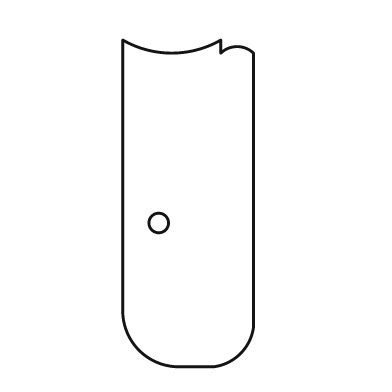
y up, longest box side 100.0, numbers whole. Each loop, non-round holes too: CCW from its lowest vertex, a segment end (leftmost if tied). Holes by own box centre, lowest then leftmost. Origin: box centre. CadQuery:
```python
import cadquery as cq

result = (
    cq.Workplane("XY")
    .moveTo(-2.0, -50.0)
    .lineTo(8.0, -50.0)
    .threePointArc((16.0, -46.0), (20.0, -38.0))
    .lineTo(20.0, 46.0)
    .threePointArc((15.0, 48.0), (10.0, 46.0))
    .lineTo(10.0, 50.0)
    .threePointArc((-5.0, 46.0), (-20.0, 50.0))
    .lineTo(-20.0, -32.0)
    .threePointArc((-15.0, -45.0), (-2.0, -50.0))
    .close()
    .moveTo(-9.0, -6.0)
    .circle(3.0)
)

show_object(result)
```